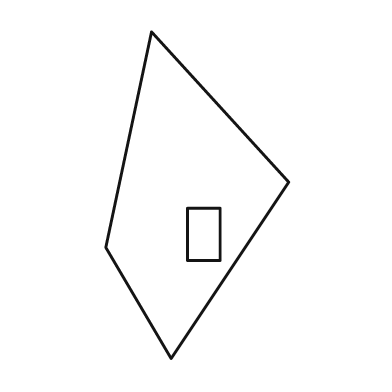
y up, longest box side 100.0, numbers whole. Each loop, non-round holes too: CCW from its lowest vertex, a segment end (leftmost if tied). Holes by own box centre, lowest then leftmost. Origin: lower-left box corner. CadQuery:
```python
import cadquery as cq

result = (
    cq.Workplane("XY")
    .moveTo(20.0, 0.0)
    .lineTo(56.0, 54.0)
    .lineTo(14.0, 100.0)
    .lineTo(0.0, 34.0)
    .close()
    .moveTo(25.0, 30.0)
    .lineTo(35.0, 30.0)
    .lineTo(35.0, 46.0)
    .lineTo(25.0, 46.0)
    .close()
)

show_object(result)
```